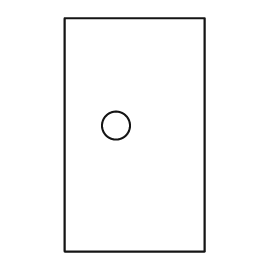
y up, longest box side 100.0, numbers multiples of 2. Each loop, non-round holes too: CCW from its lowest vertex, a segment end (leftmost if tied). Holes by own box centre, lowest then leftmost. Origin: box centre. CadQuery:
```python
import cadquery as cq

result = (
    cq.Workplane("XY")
    .moveTo(-30.0, -50.0)
    .lineTo(30.0, -50.0)
    .lineTo(30.0, 50.0)
    .lineTo(-30.0, 50.0)
    .close()
    .moveTo(-8.0, 4.0)
    .circle(6.0)
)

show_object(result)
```